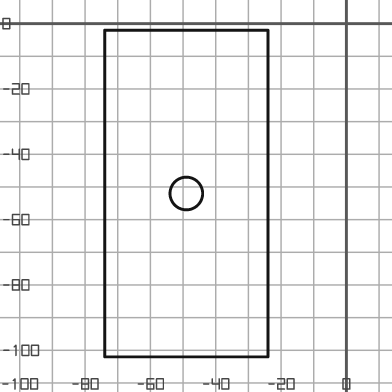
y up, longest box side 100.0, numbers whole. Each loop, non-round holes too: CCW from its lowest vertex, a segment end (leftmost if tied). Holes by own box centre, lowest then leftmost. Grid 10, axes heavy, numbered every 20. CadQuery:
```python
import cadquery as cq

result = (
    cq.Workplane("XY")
    .moveTo(-74.0, -102.0)
    .lineTo(-24.0, -102.0)
    .lineTo(-24.0, -2.0)
    .lineTo(-74.0, -2.0)
    .close()
    .moveTo(-49.0, -52.0)
    .circle(5.0)
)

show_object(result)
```